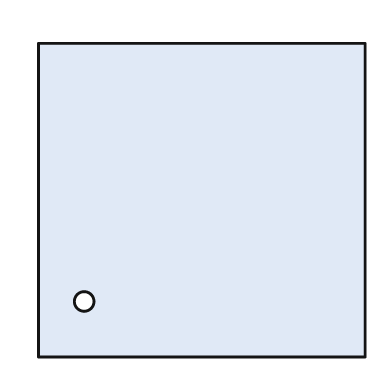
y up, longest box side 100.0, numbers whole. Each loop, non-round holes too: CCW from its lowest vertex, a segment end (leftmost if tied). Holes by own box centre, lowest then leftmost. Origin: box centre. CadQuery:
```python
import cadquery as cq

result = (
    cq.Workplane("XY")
    .moveTo(-50.0, -48.0)
    .lineTo(50.0, -48.0)
    .lineTo(50.0, 48.0)
    .lineTo(-50.0, 48.0)
    .close()
    .moveTo(-36.0, -31.0)
    .circle(3.0)
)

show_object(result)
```